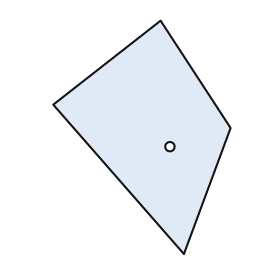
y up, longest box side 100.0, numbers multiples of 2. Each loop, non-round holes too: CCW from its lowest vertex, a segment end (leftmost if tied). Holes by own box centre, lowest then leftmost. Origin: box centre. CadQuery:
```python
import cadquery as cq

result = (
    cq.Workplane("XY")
    .moveTo(18.0, -50.0)
    .lineTo(38.0, 4.0)
    .lineTo(8.0, 50.0)
    .lineTo(-38.0, 14.0)
    .close()
    .moveTo(12.0, -4.0)
    .circle(2.0)
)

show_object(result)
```